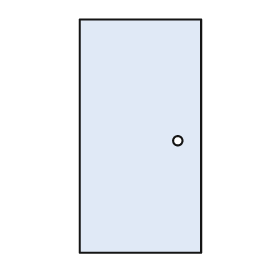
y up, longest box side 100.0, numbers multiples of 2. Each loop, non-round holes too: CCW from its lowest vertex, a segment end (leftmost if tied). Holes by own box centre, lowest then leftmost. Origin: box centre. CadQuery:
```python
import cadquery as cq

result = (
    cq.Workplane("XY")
    .moveTo(-26.0, -50.0)
    .lineTo(26.0, -50.0)
    .lineTo(26.0, 50.0)
    .lineTo(-26.0, 50.0)
    .close()
    .moveTo(16.0, -2.0)
    .circle(2.0)
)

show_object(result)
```